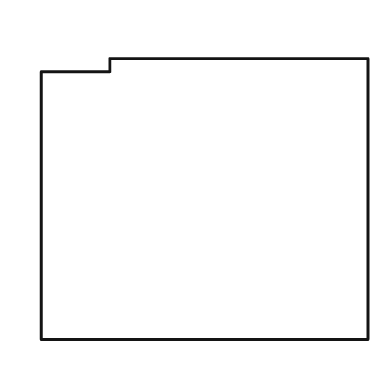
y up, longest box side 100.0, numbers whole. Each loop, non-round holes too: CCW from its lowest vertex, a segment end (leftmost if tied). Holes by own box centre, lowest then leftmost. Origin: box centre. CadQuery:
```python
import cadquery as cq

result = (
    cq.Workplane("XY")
    .moveTo(-50.0, -43.0)
    .lineTo(50.0, -43.0)
    .lineTo(50.0, 43.0)
    .lineTo(-29.0, 43.0)
    .lineTo(-29.0, 39.0)
    .lineTo(-50.0, 39.0)
    .close()
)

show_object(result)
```